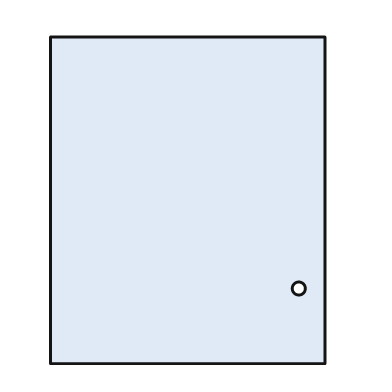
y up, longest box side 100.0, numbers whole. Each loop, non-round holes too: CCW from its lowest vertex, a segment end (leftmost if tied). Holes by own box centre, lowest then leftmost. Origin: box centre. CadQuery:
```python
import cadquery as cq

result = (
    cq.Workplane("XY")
    .moveTo(-42.0, -50.0)
    .lineTo(42.0, -50.0)
    .lineTo(42.0, 50.0)
    .lineTo(-42.0, 50.0)
    .close()
    .moveTo(34.0, -27.0)
    .circle(2.0)
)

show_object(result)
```